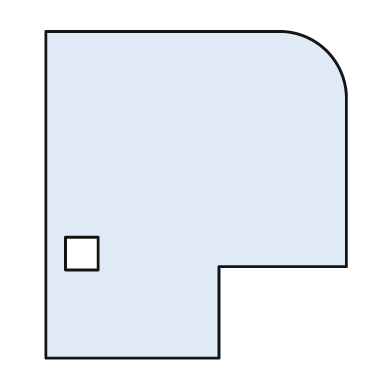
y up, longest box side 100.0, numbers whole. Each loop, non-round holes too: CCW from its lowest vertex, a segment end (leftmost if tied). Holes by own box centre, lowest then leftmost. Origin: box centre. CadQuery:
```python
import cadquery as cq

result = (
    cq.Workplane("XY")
    .moveTo(-46.0, -50.0)
    .lineTo(7.0, -50.0)
    .lineTo(7.0, -22.0)
    .lineTo(46.0, -22.0)
    .lineTo(46.0, 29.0)
    .threePointArc((40.0, 44.0), (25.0, 50.0))
    .lineTo(-46.0, 50.0)
    .close()
    .moveTo(-40.0, -23.0)
    .lineTo(-30.0, -23.0)
    .lineTo(-30.0, -13.0)
    .lineTo(-40.0, -13.0)
    .close()
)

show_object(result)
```